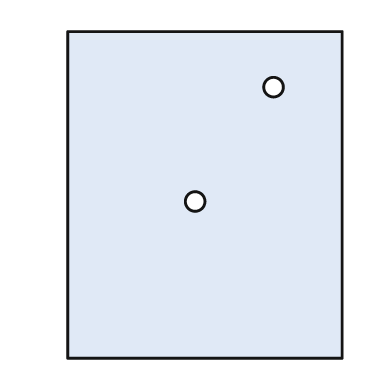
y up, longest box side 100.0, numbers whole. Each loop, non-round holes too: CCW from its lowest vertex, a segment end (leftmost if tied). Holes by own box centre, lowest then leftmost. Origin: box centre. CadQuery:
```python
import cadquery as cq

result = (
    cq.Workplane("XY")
    .moveTo(-42.0, -50.0)
    .lineTo(42.0, -50.0)
    .lineTo(42.0, 50.0)
    .lineTo(-42.0, 50.0)
    .close()
    .moveTo(-3.0, -2.0)
    .circle(3.0)
    .moveTo(21.0, 33.0)
    .circle(3.0)
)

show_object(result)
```